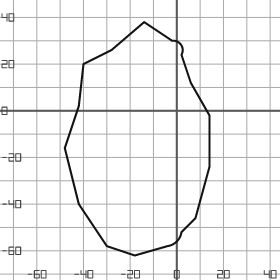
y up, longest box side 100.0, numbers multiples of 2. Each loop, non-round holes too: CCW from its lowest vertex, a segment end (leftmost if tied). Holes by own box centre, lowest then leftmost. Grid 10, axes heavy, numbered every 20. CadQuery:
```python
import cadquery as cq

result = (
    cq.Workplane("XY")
    .moveTo(-18.0, -62.0)
    .lineTo(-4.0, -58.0)
    .threePointArc((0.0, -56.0), (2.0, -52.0))
    .lineTo(8.0, -46.0)
    .lineTo(14.0, -24.0)
    .lineTo(14.0, -2.0)
    .lineTo(6.0, 12.0)
    .lineTo(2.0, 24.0)
    .threePointArc((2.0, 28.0), (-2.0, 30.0))
    .lineTo(-14.0, 38.0)
    .lineTo(-28.0, 26.0)
    .lineTo(-40.0, 20.0)
    .lineTo(-42.0, 2.0)
    .lineTo(-48.0, -16.0)
    .lineTo(-42.0, -40.0)
    .lineTo(-30.0, -58.0)
    .close()
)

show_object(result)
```